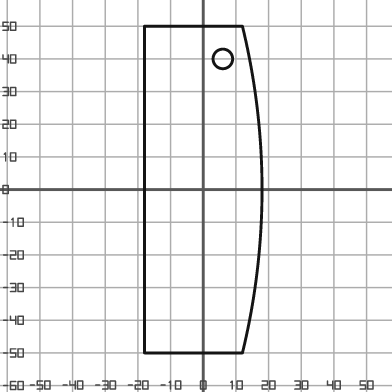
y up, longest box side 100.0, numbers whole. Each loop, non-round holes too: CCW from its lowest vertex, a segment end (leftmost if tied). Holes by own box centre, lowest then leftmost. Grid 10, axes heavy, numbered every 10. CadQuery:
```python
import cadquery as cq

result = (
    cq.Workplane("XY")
    .moveTo(-18.0, -50.0)
    .lineTo(12.0, -50.0)
    .threePointArc((18.0, 0.0), (12.0, 50.0))
    .lineTo(-18.0, 50.0)
    .close()
    .moveTo(6.0, 40.0)
    .circle(3.0)
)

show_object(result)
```